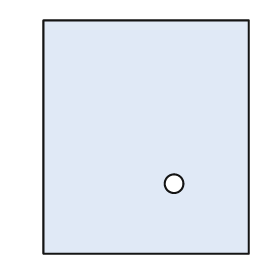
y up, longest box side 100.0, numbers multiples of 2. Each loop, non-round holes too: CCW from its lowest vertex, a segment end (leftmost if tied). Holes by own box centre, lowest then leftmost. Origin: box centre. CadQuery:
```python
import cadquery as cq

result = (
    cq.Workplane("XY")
    .moveTo(-44.0, -50.0)
    .lineTo(44.0, -50.0)
    .lineTo(44.0, 50.0)
    .lineTo(-44.0, 50.0)
    .close()
    .moveTo(12.0, -20.0)
    .circle(4.0)
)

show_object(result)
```